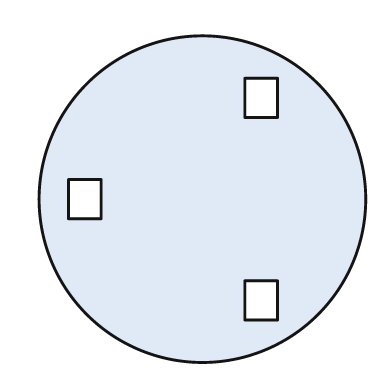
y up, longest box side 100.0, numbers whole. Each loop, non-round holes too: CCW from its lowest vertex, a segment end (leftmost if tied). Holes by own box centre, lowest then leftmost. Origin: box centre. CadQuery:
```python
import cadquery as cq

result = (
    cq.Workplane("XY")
    .moveTo(0.0, 0.0)
    .circle(50.0)
    .moveTo(13.0, -37.0)
    .lineTo(23.0, -37.0)
    .lineTo(23.0, -25.0)
    .lineTo(13.0, -25.0)
    .close()
    .moveTo(-41.0, -6.0)
    .lineTo(-31.0, -6.0)
    .lineTo(-31.0, 6.0)
    .lineTo(-41.0, 6.0)
    .close()
    .moveTo(13.0, 25.0)
    .lineTo(23.0, 25.0)
    .lineTo(23.0, 37.0)
    .lineTo(13.0, 37.0)
    .close()
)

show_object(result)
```